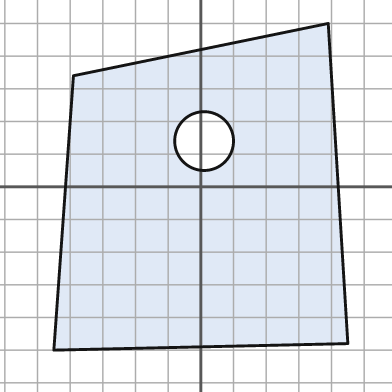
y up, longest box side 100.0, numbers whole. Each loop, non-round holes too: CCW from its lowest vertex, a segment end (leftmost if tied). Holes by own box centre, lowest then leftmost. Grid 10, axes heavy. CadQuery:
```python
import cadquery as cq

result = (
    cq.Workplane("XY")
    .moveTo(-45.0, -50.0)
    .lineTo(45.0, -48.0)
    .lineTo(39.0, 50.0)
    .lineTo(-39.0, 34.0)
    .close()
    .moveTo(1.0, 14.0)
    .circle(9.0)
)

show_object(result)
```